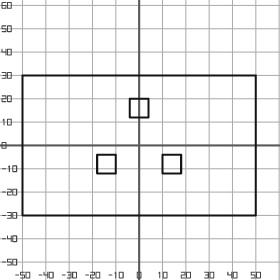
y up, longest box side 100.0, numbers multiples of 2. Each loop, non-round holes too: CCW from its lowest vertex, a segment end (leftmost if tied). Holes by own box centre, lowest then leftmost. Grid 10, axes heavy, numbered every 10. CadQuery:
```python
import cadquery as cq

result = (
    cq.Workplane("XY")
    .moveTo(-50.0, -30.0)
    .lineTo(50.0, -30.0)
    .lineTo(50.0, 30.0)
    .lineTo(-50.0, 30.0)
    .close()
    .moveTo(-18.0, -12.0)
    .lineTo(-10.0, -12.0)
    .lineTo(-10.0, -4.0)
    .lineTo(-18.0, -4.0)
    .close()
    .moveTo(10.0, -12.0)
    .lineTo(18.0, -12.0)
    .lineTo(18.0, -4.0)
    .lineTo(10.0, -4.0)
    .close()
    .moveTo(-4.0, 12.0)
    .lineTo(4.0, 12.0)
    .lineTo(4.0, 20.0)
    .lineTo(-4.0, 20.0)
    .close()
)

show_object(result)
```